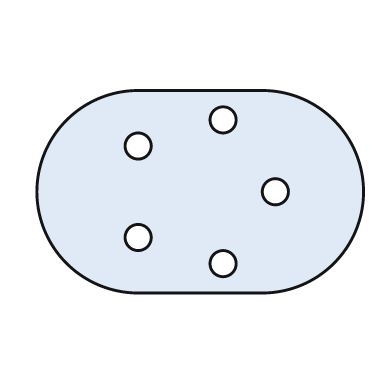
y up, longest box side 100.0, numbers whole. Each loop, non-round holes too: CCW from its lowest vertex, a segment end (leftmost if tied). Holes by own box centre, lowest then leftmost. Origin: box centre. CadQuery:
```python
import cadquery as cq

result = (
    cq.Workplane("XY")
    .moveTo(-19.0, -31.0)
    .lineTo(19.0, -31.0)
    .threePointArc((50.0, 0.0), (19.0, 31.0))
    .lineTo(-19.0, 31.0)
    .threePointArc((-50.0, 0.0), (-19.0, -31.0))
    .close()
    .moveTo(7.0, -22.0)
    .circle(4.0)
    .moveTo(-19.0, -14.0)
    .circle(4.0)
    .moveTo(23.0, 0.0)
    .circle(4.0)
    .moveTo(-19.0, 14.0)
    .circle(4.0)
    .moveTo(7.0, 22.0)
    .circle(4.0)
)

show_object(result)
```